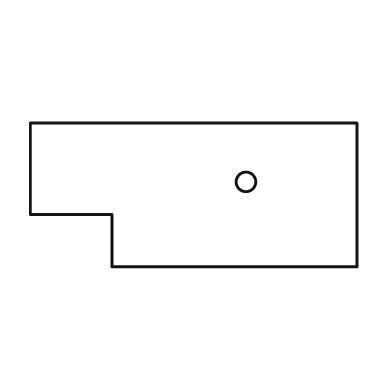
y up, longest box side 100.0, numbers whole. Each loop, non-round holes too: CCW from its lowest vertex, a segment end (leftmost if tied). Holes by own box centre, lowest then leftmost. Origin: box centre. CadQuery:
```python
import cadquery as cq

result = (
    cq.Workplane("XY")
    .moveTo(-25.0, -22.0)
    .lineTo(50.0, -22.0)
    .lineTo(50.0, 22.0)
    .lineTo(-50.0, 22.0)
    .lineTo(-50.0, -6.0)
    .lineTo(-25.0, -6.0)
    .close()
    .moveTo(16.0, 4.0)
    .circle(3.0)
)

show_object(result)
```